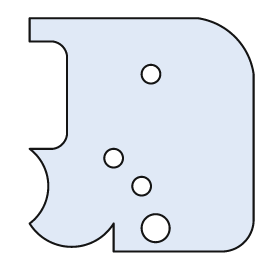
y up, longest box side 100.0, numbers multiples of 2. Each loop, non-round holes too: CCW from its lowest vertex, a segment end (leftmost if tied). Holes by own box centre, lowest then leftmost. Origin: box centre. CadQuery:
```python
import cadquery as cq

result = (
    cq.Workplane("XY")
    .moveTo(-12.0, -50.0)
    .lineTo(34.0, -50.0)
    .threePointArc((44.0, -46.0), (48.0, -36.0))
    .lineTo(48.0, 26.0)
    .threePointArc((40.0, 42.0), (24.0, 50.0))
    .lineTo(-48.0, 50.0)
    .lineTo(-48.0, 40.0)
    .lineTo(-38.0, 40.0)
    .threePointArc((-34.0, 38.0), (-32.0, 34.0))
    .lineTo(-32.0, 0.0)
    .threePointArc((-34.0, -4.0), (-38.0, -6.0))
    .lineTo(-48.0, -6.0)
    .threePointArc((-40.0, -22.0), (-48.0, -38.0))
    .threePointArc((-30.0, -48.0), (-12.0, -38.0))
    .close()
    .moveTo(6.0, -40.0)
    .circle(6.0)
    .moveTo(0.0, -22.0)
    .circle(4.0)
    .moveTo(-12.0, -10.0)
    .circle(4.0)
    .moveTo(4.0, 26.0)
    .circle(4.0)
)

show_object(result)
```